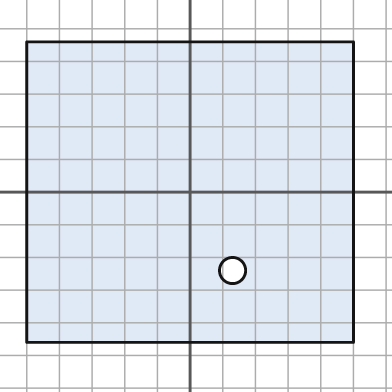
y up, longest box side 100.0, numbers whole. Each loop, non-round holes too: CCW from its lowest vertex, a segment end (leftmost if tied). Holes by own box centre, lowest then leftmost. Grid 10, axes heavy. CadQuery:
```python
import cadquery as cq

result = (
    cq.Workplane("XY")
    .moveTo(-50.0, -46.0)
    .lineTo(50.0, -46.0)
    .lineTo(50.0, 46.0)
    .lineTo(-50.0, 46.0)
    .close()
    .moveTo(13.0, -24.0)
    .circle(4.0)
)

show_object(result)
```